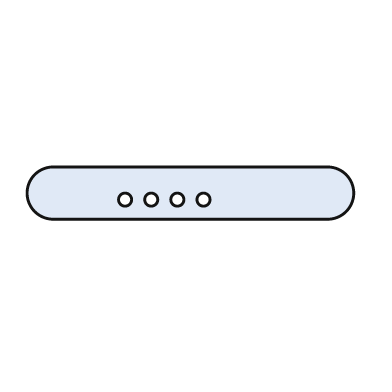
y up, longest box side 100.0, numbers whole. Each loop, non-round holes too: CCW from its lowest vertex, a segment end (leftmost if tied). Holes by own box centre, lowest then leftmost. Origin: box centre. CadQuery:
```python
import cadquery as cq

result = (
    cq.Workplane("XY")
    .moveTo(-42.0, -8.0)
    .lineTo(42.0, -8.0)
    .threePointArc((50.0, 0.0), (42.0, 8.0))
    .lineTo(-42.0, 8.0)
    .threePointArc((-50.0, 0.0), (-42.0, -8.0))
    .close()
    .moveTo(-20.0, -2.0)
    .circle(2.0)
    .moveTo(-12.0, -2.0)
    .circle(2.0)
    .moveTo(-4.0, -2.0)
    .circle(2.0)
    .moveTo(4.0, -2.0)
    .circle(2.0)
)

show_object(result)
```